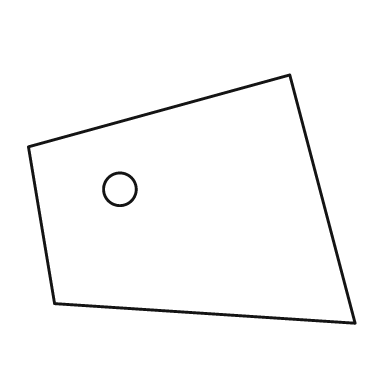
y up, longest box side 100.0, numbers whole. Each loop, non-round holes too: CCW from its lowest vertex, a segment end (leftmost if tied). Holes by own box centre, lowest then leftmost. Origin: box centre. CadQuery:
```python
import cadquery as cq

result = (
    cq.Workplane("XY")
    .moveTo(50.0, -38.0)
    .lineTo(30.0, 38.0)
    .lineTo(-50.0, 16.0)
    .lineTo(-42.0, -32.0)
    .close()
    .moveTo(-22.0, 3.0)
    .circle(5.0)
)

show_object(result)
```